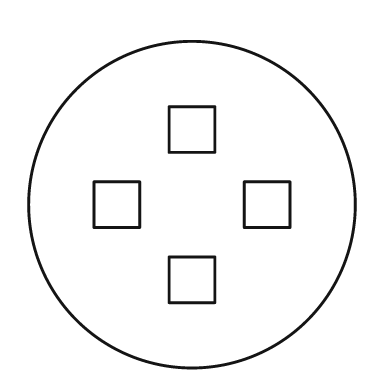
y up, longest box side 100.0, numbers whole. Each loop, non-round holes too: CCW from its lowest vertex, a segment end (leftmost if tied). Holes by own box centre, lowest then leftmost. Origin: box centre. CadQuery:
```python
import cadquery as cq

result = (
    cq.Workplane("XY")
    .moveTo(0.0, 0.0)
    .circle(50.0)
    .moveTo(-7.0, -30.0)
    .lineTo(7.0, -30.0)
    .lineTo(7.0, -16.0)
    .lineTo(-7.0, -16.0)
    .close()
    .moveTo(-30.0, -7.0)
    .lineTo(-16.0, -7.0)
    .lineTo(-16.0, 7.0)
    .lineTo(-30.0, 7.0)
    .close()
    .moveTo(16.0, -7.0)
    .lineTo(30.0, -7.0)
    .lineTo(30.0, 7.0)
    .lineTo(16.0, 7.0)
    .close()
    .moveTo(-7.0, 16.0)
    .lineTo(7.0, 16.0)
    .lineTo(7.0, 30.0)
    .lineTo(-7.0, 30.0)
    .close()
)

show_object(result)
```